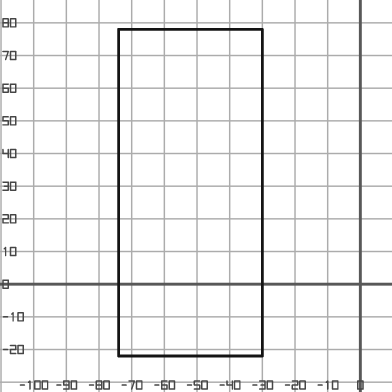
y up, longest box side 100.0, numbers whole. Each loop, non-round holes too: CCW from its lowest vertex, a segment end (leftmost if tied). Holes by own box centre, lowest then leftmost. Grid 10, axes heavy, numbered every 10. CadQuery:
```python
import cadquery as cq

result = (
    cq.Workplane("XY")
    .moveTo(-74.0, -22.0)
    .lineTo(-30.0, -22.0)
    .lineTo(-30.0, 78.0)
    .lineTo(-74.0, 78.0)
    .close()
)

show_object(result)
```